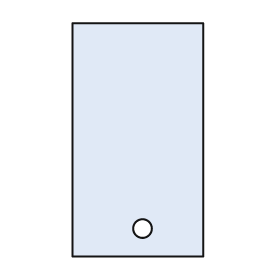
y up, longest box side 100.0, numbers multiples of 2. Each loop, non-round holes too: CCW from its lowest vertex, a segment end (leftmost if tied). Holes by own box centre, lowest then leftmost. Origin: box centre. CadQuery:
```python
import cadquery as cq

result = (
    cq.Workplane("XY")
    .moveTo(-28.0, -50.0)
    .lineTo(28.0, -50.0)
    .lineTo(28.0, 50.0)
    .lineTo(-28.0, 50.0)
    .close()
    .moveTo(2.0, -38.0)
    .circle(4.0)
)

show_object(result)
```